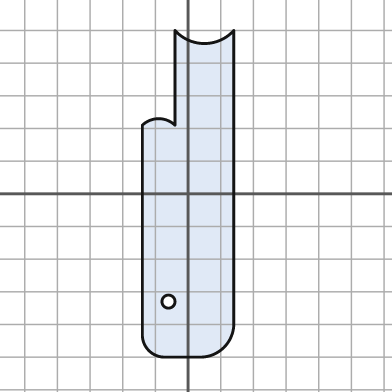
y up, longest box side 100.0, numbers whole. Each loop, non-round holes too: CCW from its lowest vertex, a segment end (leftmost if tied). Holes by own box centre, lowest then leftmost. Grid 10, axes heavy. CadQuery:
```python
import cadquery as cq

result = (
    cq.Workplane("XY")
    .moveTo(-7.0, -50.0)
    .lineTo(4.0, -50.0)
    .threePointArc((11.0, -47.0), (14.0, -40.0))
    .lineTo(14.0, 50.0)
    .threePointArc((5.0, 46.0), (-4.0, 50.0))
    .lineTo(-4.0, 21.0)
    .threePointArc((-9.0, 23.0), (-14.0, 21.0))
    .lineTo(-14.0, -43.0)
    .threePointArc((-12.0, -48.0), (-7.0, -50.0))
    .close()
    .moveTo(-6.0, -33.0)
    .circle(2.0)
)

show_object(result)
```